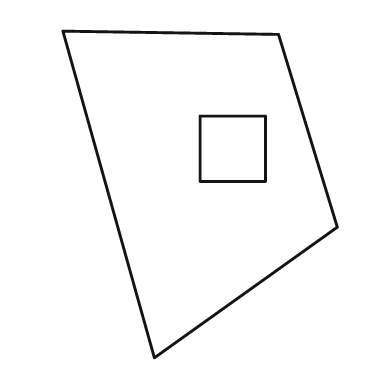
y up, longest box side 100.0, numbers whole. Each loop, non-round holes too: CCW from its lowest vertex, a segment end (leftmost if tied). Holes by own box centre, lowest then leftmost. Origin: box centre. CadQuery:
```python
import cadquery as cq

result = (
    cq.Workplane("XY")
    .moveTo(-14.0, -50.0)
    .lineTo(42.0, -10.0)
    .lineTo(24.0, 49.0)
    .lineTo(-42.0, 50.0)
    .close()
    .moveTo(0.0, 4.0)
    .lineTo(20.0, 4.0)
    .lineTo(20.0, 24.0)
    .lineTo(0.0, 24.0)
    .close()
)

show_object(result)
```